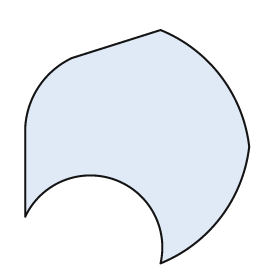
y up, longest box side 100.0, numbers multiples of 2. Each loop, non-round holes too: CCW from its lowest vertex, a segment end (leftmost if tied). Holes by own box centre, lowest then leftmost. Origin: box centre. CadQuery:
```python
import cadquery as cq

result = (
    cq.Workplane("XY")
    .moveTo(10.0, -50.0)
    .threePointArc((36.0, -30.0), (48.0, 0.0))
    .threePointArc((36.0, 30.0), (10.0, 50.0))
    .lineTo(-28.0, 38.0)
    .threePointArc((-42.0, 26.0), (-48.0, 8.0))
    .lineTo(-48.0, -30.0)
    .threePointArc((-10.0, -14.0), (10.0, -50.0))
    .close()
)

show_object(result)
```